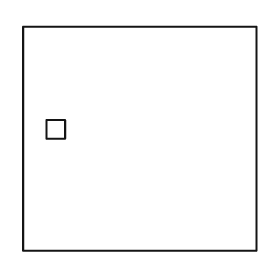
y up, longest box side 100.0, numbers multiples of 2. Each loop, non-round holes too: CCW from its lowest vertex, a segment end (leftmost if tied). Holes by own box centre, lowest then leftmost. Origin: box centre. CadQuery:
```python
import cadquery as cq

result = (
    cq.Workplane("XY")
    .moveTo(-50.0, -48.0)
    .lineTo(50.0, -48.0)
    .lineTo(50.0, 48.0)
    .lineTo(-50.0, 48.0)
    .close()
    .moveTo(-40.0, 0.0)
    .lineTo(-32.0, 0.0)
    .lineTo(-32.0, 8.0)
    .lineTo(-40.0, 8.0)
    .close()
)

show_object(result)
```